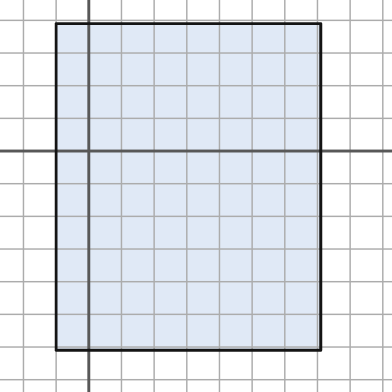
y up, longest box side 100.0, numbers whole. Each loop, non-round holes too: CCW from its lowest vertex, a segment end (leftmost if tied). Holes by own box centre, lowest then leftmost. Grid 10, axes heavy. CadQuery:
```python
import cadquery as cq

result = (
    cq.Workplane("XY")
    .moveTo(-10.0, -61.0)
    .lineTo(71.0, -61.0)
    .lineTo(71.0, 39.0)
    .lineTo(-10.0, 39.0)
    .close()
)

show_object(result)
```